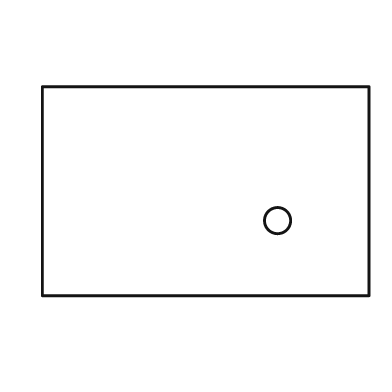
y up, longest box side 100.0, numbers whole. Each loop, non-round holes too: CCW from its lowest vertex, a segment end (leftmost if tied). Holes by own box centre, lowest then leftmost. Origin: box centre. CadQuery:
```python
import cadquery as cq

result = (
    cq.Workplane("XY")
    .moveTo(-50.0, -32.0)
    .lineTo(50.0, -32.0)
    .lineTo(50.0, 32.0)
    .lineTo(-50.0, 32.0)
    .close()
    .moveTo(22.0, -9.0)
    .circle(4.0)
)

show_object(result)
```